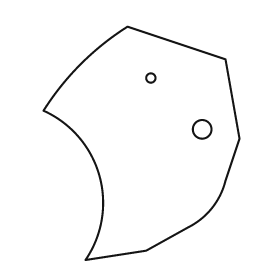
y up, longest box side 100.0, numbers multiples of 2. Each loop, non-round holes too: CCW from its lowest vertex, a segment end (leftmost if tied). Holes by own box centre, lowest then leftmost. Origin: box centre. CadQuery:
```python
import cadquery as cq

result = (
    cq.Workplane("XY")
    .moveTo(-24.0, -50.0)
    .lineTo(2.0, -46.0)
    .lineTo(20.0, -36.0)
    .threePointArc((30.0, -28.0), (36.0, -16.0))
    .lineTo(42.0, 2.0)
    .lineTo(36.0, 36.0)
    .lineTo(-6.0, 50.0)
    .threePointArc((-26.0, 34.0), (-42.0, 14.0))
    .threePointArc((-18.0, -14.0), (-24.0, -50.0))
    .close()
    .moveTo(26.0, 6.0)
    .circle(4.0)
    .moveTo(4.0, 28.0)
    .circle(2.0)
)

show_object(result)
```